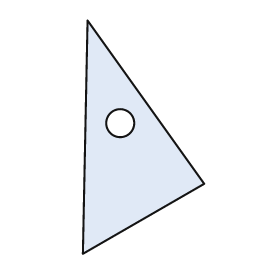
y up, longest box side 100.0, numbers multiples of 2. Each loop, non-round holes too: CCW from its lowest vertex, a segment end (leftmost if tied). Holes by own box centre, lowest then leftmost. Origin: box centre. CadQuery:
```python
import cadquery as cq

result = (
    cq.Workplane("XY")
    .moveTo(-26.0, -50.0)
    .lineTo(26.0, -20.0)
    .lineTo(-24.0, 50.0)
    .close()
    .moveTo(-10.0, 6.0)
    .circle(6.0)
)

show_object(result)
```